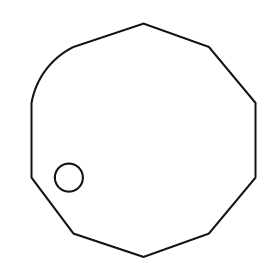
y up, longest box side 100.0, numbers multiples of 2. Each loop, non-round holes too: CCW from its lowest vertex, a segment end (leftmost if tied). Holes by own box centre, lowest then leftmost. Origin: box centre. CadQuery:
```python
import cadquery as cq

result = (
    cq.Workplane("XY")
    .moveTo(0.0, -50.0)
    .lineTo(28.0, -40.0)
    .lineTo(48.0, -16.0)
    .lineTo(48.0, 16.0)
    .lineTo(28.0, 40.0)
    .lineTo(0.0, 50.0)
    .lineTo(-30.0, 40.0)
    .threePointArc((-42.0, 30.0), (-48.0, 16.0))
    .lineTo(-48.0, -16.0)
    .lineTo(-30.0, -40.0)
    .close()
    .moveTo(-32.0, -16.0)
    .circle(6.0)
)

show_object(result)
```